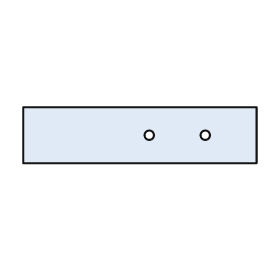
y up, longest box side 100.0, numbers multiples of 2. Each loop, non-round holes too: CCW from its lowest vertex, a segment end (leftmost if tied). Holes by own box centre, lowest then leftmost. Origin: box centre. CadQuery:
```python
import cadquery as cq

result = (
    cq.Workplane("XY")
    .moveTo(-50.0, -12.0)
    .lineTo(50.0, -12.0)
    .lineTo(50.0, 12.0)
    .lineTo(-50.0, 12.0)
    .close()
    .moveTo(4.0, 0.0)
    .circle(2.0)
    .moveTo(28.0, 0.0)
    .circle(2.0)
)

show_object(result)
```